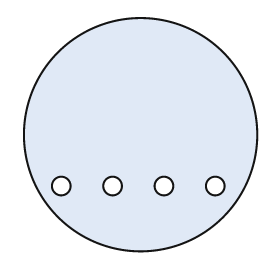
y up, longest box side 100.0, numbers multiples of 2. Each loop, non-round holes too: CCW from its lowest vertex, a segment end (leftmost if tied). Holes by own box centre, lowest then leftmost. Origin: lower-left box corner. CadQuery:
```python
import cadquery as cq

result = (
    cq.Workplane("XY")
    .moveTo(50.0, 50.0)
    .circle(50.0)
    .moveTo(16.0, 28.0)
    .circle(4.0)
    .moveTo(38.0, 28.0)
    .circle(4.0)
    .moveTo(60.0, 28.0)
    .circle(4.0)
    .moveTo(82.0, 28.0)
    .circle(4.0)
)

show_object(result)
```